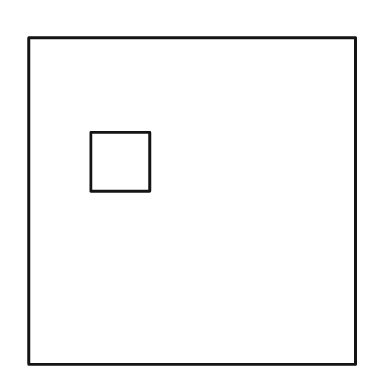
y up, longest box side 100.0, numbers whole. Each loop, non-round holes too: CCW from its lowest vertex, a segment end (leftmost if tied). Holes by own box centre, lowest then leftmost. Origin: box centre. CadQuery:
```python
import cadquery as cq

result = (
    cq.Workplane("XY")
    .moveTo(-50.0, -50.0)
    .lineTo(50.0, -50.0)
    .lineTo(50.0, 50.0)
    .lineTo(-50.0, 50.0)
    .close()
    .moveTo(-31.0, 3.0)
    .lineTo(-13.0, 3.0)
    .lineTo(-13.0, 21.0)
    .lineTo(-31.0, 21.0)
    .close()
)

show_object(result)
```